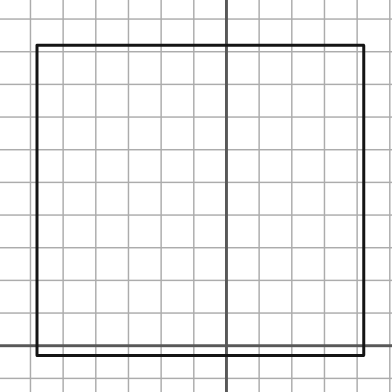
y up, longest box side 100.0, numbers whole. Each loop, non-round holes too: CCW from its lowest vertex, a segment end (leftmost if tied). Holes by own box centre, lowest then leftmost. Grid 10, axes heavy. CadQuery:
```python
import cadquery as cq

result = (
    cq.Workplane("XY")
    .moveTo(-58.0, -3.0)
    .lineTo(42.0, -3.0)
    .lineTo(42.0, 92.0)
    .lineTo(-58.0, 92.0)
    .close()
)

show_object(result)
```